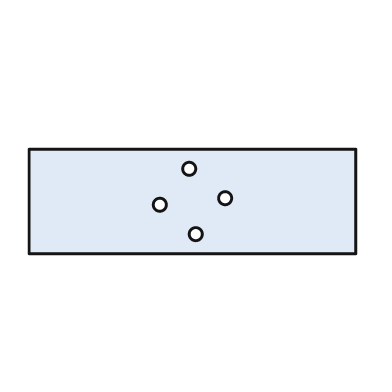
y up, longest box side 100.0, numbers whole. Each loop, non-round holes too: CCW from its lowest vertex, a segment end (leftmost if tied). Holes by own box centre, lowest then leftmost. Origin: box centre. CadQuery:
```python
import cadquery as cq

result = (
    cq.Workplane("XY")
    .moveTo(-50.0, -16.0)
    .lineTo(50.0, -16.0)
    .lineTo(50.0, 16.0)
    .lineTo(-50.0, 16.0)
    .close()
    .moveTo(1.0, -10.0)
    .circle(2.0)
    .moveTo(-10.0, -1.0)
    .circle(2.0)
    .moveTo(10.0, 1.0)
    .circle(2.0)
    .moveTo(-1.0, 10.0)
    .circle(2.0)
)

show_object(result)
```